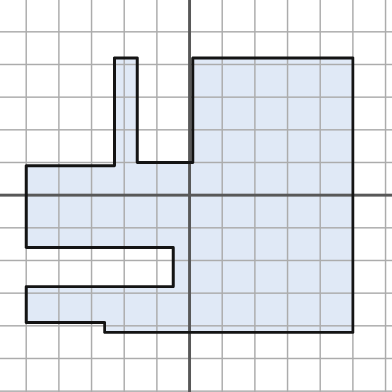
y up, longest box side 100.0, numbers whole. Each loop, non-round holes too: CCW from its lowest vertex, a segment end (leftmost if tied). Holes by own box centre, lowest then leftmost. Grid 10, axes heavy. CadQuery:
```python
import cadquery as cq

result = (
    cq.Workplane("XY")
    .moveTo(-26.0, -42.0)
    .lineTo(50.0, -42.0)
    .lineTo(50.0, 42.0)
    .lineTo(1.0, 42.0)
    .lineTo(1.0, 10.0)
    .lineTo(-16.0, 10.0)
    .lineTo(-16.0, 42.0)
    .lineTo(-23.0, 42.0)
    .lineTo(-23.0, 9.0)
    .lineTo(-50.0, 9.0)
    .lineTo(-50.0, -16.0)
    .lineTo(-5.0, -16.0)
    .lineTo(-5.0, -28.0)
    .lineTo(-50.0, -28.0)
    .lineTo(-50.0, -39.0)
    .lineTo(-26.0, -39.0)
    .close()
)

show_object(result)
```